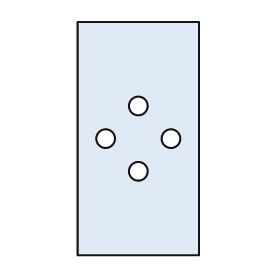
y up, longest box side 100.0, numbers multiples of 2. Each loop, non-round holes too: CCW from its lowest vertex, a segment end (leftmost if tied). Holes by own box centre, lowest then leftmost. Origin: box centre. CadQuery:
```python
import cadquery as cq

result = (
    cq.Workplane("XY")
    .moveTo(-26.0, -50.0)
    .lineTo(26.0, -50.0)
    .lineTo(26.0, 50.0)
    .lineTo(-26.0, 50.0)
    .close()
    .moveTo(0.0, -14.0)
    .circle(4.0)
    .moveTo(-14.0, 0.0)
    .circle(4.0)
    .moveTo(14.0, 0.0)
    .circle(4.0)
    .moveTo(0.0, 14.0)
    .circle(4.0)
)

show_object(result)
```